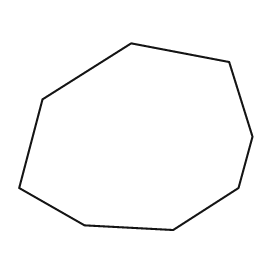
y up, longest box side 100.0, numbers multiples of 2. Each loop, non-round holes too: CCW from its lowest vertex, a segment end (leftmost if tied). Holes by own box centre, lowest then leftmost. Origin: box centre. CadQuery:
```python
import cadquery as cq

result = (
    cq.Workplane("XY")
    .moveTo(16.0, -40.0)
    .lineTo(44.0, -22.0)
    .lineTo(50.0, 0.0)
    .lineTo(40.0, 32.0)
    .lineTo(-2.0, 40.0)
    .lineTo(-40.0, 16.0)
    .lineTo(-50.0, -22.0)
    .lineTo(-22.0, -38.0)
    .close()
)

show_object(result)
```